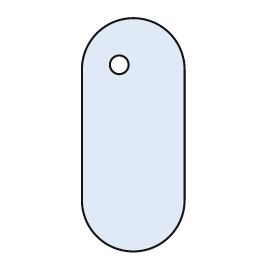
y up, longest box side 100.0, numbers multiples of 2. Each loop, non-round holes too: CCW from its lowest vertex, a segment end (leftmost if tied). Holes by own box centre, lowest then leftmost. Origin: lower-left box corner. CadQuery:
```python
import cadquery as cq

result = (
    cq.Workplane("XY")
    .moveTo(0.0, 22.0)
    .threePointArc((22.0, 0.0), (44.0, 22.0))
    .lineTo(44.0, 78.0)
    .threePointArc((22.0, 100.0), (0.0, 78.0))
    .close()
    .moveTo(16.0, 80.0)
    .circle(4.0)
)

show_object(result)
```